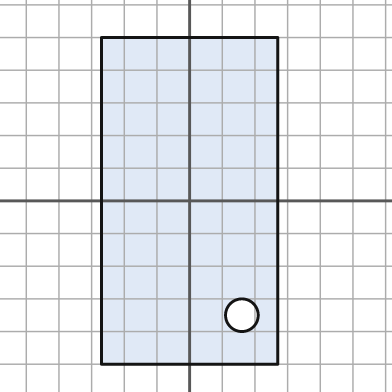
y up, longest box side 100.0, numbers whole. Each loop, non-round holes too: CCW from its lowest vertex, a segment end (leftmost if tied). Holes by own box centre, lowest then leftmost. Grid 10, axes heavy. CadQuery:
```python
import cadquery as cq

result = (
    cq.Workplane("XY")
    .moveTo(-27.0, -50.0)
    .lineTo(27.0, -50.0)
    .lineTo(27.0, 50.0)
    .lineTo(-27.0, 50.0)
    .close()
    .moveTo(16.0, -35.0)
    .circle(5.0)
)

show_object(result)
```